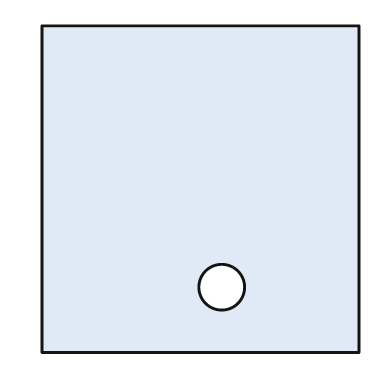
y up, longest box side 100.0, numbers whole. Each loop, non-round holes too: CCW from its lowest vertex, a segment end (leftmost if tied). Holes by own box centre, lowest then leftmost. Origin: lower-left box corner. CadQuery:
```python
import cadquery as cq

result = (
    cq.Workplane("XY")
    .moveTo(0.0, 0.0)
    .lineTo(97.0, 0.0)
    .lineTo(97.0, 100.0)
    .lineTo(0.0, 100.0)
    .close()
    .moveTo(55.0, 20.0)
    .circle(7.0)
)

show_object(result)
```